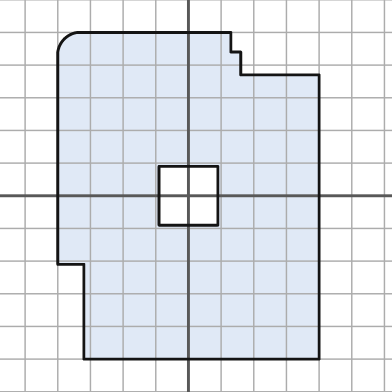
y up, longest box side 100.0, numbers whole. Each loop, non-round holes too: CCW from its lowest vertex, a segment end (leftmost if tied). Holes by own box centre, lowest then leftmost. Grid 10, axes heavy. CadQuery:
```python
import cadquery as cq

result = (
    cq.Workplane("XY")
    .moveTo(-32.0, -50.0)
    .lineTo(40.0, -50.0)
    .lineTo(40.0, 37.0)
    .lineTo(16.0, 37.0)
    .lineTo(16.0, 44.0)
    .lineTo(13.0, 44.0)
    .lineTo(13.0, 50.0)
    .lineTo(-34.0, 50.0)
    .threePointArc((-38.0, 48.0), (-40.0, 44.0))
    .lineTo(-40.0, -21.0)
    .lineTo(-32.0, -21.0)
    .close()
    .moveTo(-9.0, -9.0)
    .lineTo(9.0, -9.0)
    .lineTo(9.0, 9.0)
    .lineTo(-9.0, 9.0)
    .close()
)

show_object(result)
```